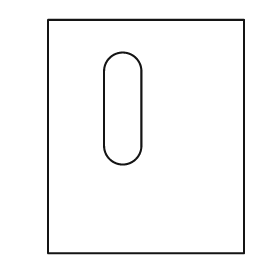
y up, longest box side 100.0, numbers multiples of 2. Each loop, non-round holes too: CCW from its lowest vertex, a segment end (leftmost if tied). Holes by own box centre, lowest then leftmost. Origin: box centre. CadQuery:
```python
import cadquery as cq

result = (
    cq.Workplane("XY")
    .moveTo(-42.0, -50.0)
    .lineTo(42.0, -50.0)
    .lineTo(42.0, 50.0)
    .lineTo(-42.0, 50.0)
    .close()
    .moveTo(-18.0, -4.0)
    .threePointArc((-10.0, -12.0), (-2.0, -4.0))
    .lineTo(-2.0, 28.0)
    .threePointArc((-10.0, 36.0), (-18.0, 28.0))
    .close()
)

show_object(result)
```